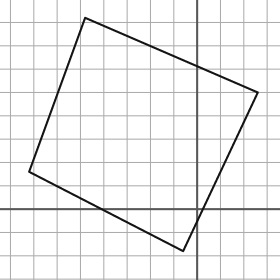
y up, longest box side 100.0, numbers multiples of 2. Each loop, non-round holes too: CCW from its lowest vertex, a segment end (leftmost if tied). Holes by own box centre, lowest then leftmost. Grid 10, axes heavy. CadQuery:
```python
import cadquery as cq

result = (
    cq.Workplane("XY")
    .moveTo(-6.0, -18.0)
    .lineTo(26.0, 50.0)
    .lineTo(-48.0, 82.0)
    .lineTo(-72.0, 16.0)
    .close()
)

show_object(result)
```